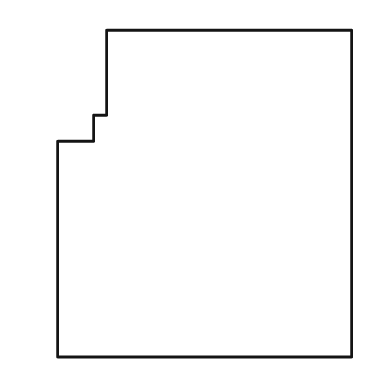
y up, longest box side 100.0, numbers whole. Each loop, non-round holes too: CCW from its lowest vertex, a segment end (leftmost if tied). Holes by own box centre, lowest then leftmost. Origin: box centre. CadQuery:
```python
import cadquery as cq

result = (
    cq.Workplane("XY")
    .moveTo(-45.0, -50.0)
    .lineTo(45.0, -50.0)
    .lineTo(45.0, 50.0)
    .lineTo(-30.0, 50.0)
    .lineTo(-30.0, 24.0)
    .lineTo(-34.0, 24.0)
    .lineTo(-34.0, 16.0)
    .lineTo(-45.0, 16.0)
    .close()
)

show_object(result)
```